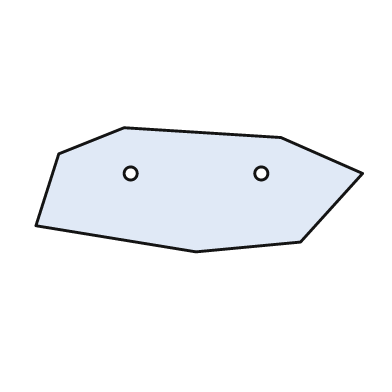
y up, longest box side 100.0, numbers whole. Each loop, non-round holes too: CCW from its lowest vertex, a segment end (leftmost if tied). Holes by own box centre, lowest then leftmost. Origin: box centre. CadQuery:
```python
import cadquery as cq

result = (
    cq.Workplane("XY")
    .moveTo(-1.0, -19.0)
    .lineTo(31.0, -16.0)
    .lineTo(50.0, 5.0)
    .lineTo(25.0, 16.0)
    .lineTo(-23.0, 19.0)
    .lineTo(-43.0, 11.0)
    .lineTo(-50.0, -11.0)
    .close()
    .moveTo(-21.0, 5.0)
    .circle(2.0)
    .moveTo(19.0, 5.0)
    .circle(2.0)
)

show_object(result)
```